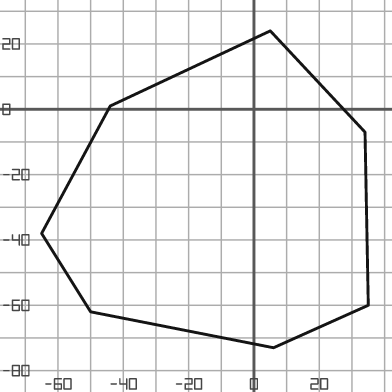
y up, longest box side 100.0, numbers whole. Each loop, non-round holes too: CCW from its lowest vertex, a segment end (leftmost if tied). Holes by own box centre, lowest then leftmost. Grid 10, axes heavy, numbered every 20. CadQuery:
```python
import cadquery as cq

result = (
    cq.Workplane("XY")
    .moveTo(6.0, -73.0)
    .lineTo(35.0, -60.0)
    .lineTo(34.0, -7.0)
    .lineTo(5.0, 24.0)
    .lineTo(-44.0, 1.0)
    .lineTo(-65.0, -38.0)
    .lineTo(-50.0, -62.0)
    .close()
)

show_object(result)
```